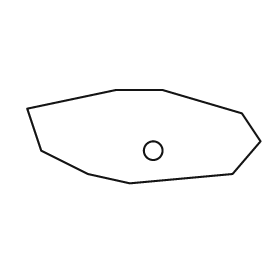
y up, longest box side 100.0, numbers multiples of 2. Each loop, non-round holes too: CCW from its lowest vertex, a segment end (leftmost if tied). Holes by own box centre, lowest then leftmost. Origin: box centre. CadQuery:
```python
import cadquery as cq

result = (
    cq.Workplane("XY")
    .moveTo(-6.0, -20.0)
    .lineTo(38.0, -16.0)
    .lineTo(50.0, -2.0)
    .lineTo(42.0, 10.0)
    .lineTo(8.0, 20.0)
    .lineTo(-12.0, 20.0)
    .lineTo(-50.0, 12.0)
    .lineTo(-44.0, -6.0)
    .lineTo(-24.0, -16.0)
    .close()
    .moveTo(4.0, -6.0)
    .circle(4.0)
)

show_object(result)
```